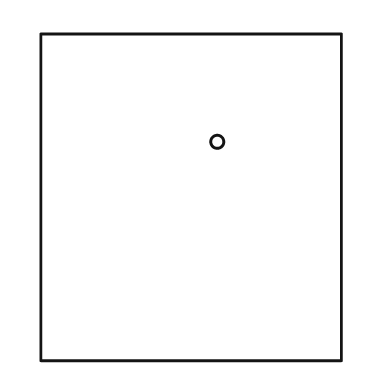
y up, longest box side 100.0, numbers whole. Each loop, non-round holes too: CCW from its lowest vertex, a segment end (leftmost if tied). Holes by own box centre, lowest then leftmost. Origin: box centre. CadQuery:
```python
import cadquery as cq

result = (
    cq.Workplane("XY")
    .moveTo(-46.0, -50.0)
    .lineTo(46.0, -50.0)
    .lineTo(46.0, 50.0)
    .lineTo(-46.0, 50.0)
    .close()
    .moveTo(8.0, 17.0)
    .circle(2.0)
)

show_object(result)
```